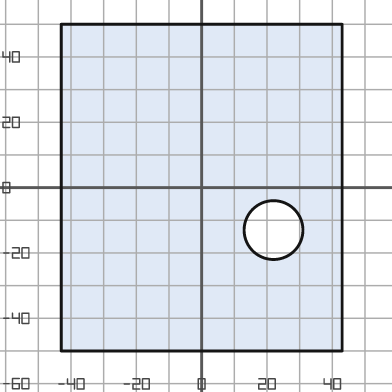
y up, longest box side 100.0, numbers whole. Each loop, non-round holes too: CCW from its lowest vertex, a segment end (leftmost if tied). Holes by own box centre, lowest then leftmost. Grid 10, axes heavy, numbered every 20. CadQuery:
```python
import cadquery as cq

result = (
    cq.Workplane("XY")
    .moveTo(-43.0, -50.0)
    .lineTo(43.0, -50.0)
    .lineTo(43.0, 50.0)
    .lineTo(-43.0, 50.0)
    .close()
    .moveTo(22.0, -13.0)
    .circle(9.0)
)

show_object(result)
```